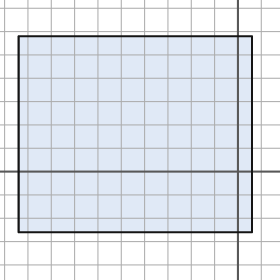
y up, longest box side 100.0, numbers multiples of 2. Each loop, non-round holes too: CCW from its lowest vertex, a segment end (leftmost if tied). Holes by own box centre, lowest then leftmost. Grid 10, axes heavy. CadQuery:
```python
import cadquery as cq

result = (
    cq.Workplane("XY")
    .moveTo(-94.0, -26.0)
    .lineTo(6.0, -26.0)
    .lineTo(6.0, 58.0)
    .lineTo(-94.0, 58.0)
    .close()
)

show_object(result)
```